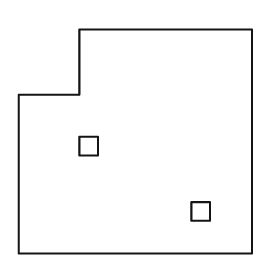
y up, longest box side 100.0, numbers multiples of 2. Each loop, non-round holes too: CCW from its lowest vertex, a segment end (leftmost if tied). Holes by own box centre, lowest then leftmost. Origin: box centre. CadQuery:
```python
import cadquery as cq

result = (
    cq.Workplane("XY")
    .moveTo(-50.0, -48.0)
    .lineTo(50.0, -48.0)
    .lineTo(50.0, 48.0)
    .lineTo(-24.0, 48.0)
    .lineTo(-24.0, 20.0)
    .lineTo(-50.0, 20.0)
    .close()
    .moveTo(24.0, -34.0)
    .lineTo(32.0, -34.0)
    .lineTo(32.0, -26.0)
    .lineTo(24.0, -26.0)
    .close()
    .moveTo(-24.0, -6.0)
    .lineTo(-16.0, -6.0)
    .lineTo(-16.0, 2.0)
    .lineTo(-24.0, 2.0)
    .close()
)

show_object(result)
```